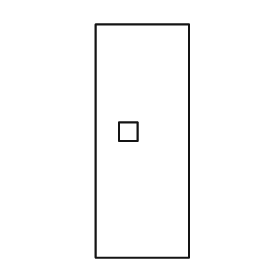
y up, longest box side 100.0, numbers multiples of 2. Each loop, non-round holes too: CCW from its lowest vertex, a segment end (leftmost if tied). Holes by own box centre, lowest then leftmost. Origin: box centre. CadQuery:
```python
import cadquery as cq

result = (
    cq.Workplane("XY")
    .moveTo(-20.0, -50.0)
    .lineTo(20.0, -50.0)
    .lineTo(20.0, 50.0)
    .lineTo(-20.0, 50.0)
    .close()
    .moveTo(-10.0, 0.0)
    .lineTo(-2.0, 0.0)
    .lineTo(-2.0, 8.0)
    .lineTo(-10.0, 8.0)
    .close()
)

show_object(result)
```